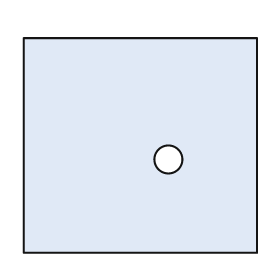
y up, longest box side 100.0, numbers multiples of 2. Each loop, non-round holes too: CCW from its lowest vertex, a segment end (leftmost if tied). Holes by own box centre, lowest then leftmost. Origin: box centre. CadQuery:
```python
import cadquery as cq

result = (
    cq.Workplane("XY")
    .moveTo(-50.0, -46.0)
    .lineTo(50.0, -46.0)
    .lineTo(50.0, 46.0)
    .lineTo(-50.0, 46.0)
    .close()
    .moveTo(12.0, -6.0)
    .circle(6.0)
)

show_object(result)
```